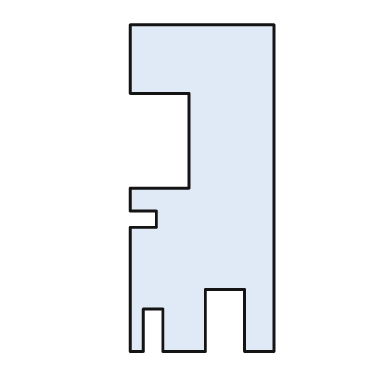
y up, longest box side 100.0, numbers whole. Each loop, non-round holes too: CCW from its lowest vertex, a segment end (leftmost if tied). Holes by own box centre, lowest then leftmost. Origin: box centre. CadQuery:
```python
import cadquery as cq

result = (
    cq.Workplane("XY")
    .moveTo(-22.0, -50.0)
    .lineTo(-18.0, -50.0)
    .lineTo(-18.0, -37.0)
    .lineTo(-12.0, -37.0)
    .lineTo(-12.0, -50.0)
    .lineTo(1.0, -50.0)
    .lineTo(1.0, -31.0)
    .lineTo(13.0, -31.0)
    .lineTo(13.0, -50.0)
    .lineTo(22.0, -50.0)
    .lineTo(22.0, 50.0)
    .lineTo(-22.0, 50.0)
    .lineTo(-22.0, 29.0)
    .lineTo(-4.0, 29.0)
    .lineTo(-4.0, 0.0)
    .lineTo(-22.0, 0.0)
    .lineTo(-22.0, -7.0)
    .lineTo(-14.0, -7.0)
    .lineTo(-14.0, -12.0)
    .lineTo(-22.0, -12.0)
    .close()
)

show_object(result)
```